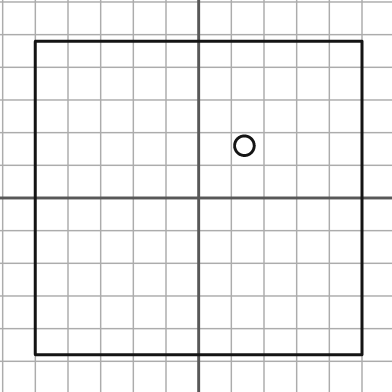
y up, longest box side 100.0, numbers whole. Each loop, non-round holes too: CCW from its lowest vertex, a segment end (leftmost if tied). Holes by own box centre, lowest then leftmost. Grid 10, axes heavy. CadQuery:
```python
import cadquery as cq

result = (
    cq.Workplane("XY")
    .moveTo(-50.0, -48.0)
    .lineTo(50.0, -48.0)
    .lineTo(50.0, 48.0)
    .lineTo(-50.0, 48.0)
    .close()
    .moveTo(14.0, 16.0)
    .circle(3.0)
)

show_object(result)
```